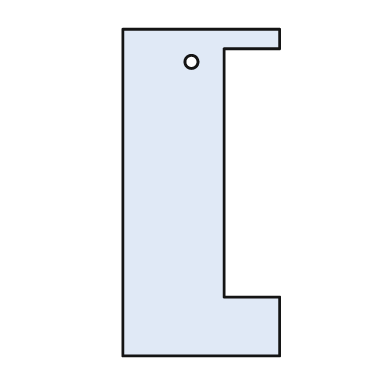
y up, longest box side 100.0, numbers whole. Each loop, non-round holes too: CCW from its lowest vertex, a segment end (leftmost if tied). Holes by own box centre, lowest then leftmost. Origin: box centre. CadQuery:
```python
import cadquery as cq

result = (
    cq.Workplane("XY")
    .moveTo(-24.0, -50.0)
    .lineTo(24.0, -50.0)
    .lineTo(24.0, -32.0)
    .lineTo(7.0, -32.0)
    .lineTo(7.0, 44.0)
    .lineTo(24.0, 44.0)
    .lineTo(24.0, 50.0)
    .lineTo(-24.0, 50.0)
    .close()
    .moveTo(-3.0, 40.0)
    .circle(2.0)
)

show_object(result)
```